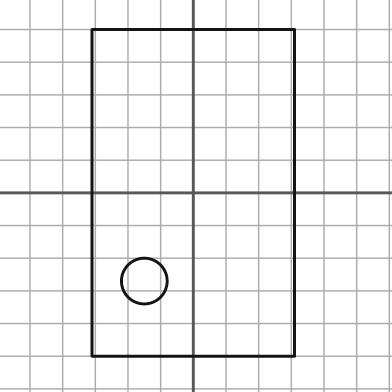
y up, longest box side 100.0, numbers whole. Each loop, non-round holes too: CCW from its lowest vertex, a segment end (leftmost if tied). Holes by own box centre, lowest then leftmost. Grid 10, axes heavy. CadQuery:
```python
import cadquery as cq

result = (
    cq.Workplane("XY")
    .moveTo(-31.0, -50.0)
    .lineTo(31.0, -50.0)
    .lineTo(31.0, 50.0)
    .lineTo(-31.0, 50.0)
    .close()
    .moveTo(-15.0, -27.0)
    .circle(7.0)
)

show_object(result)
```